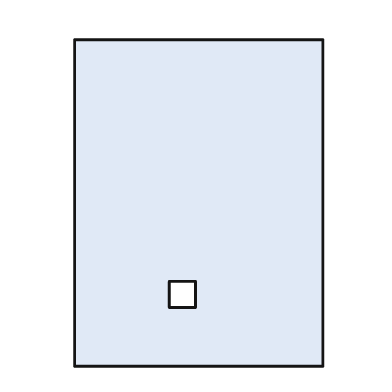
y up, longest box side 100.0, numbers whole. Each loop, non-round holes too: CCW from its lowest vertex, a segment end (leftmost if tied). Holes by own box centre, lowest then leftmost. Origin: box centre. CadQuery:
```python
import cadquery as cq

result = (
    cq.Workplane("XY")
    .moveTo(-38.0, -50.0)
    .lineTo(38.0, -50.0)
    .lineTo(38.0, 50.0)
    .lineTo(-38.0, 50.0)
    .close()
    .moveTo(-9.0, -32.0)
    .lineTo(-1.0, -32.0)
    .lineTo(-1.0, -24.0)
    .lineTo(-9.0, -24.0)
    .close()
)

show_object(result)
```